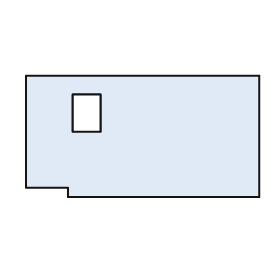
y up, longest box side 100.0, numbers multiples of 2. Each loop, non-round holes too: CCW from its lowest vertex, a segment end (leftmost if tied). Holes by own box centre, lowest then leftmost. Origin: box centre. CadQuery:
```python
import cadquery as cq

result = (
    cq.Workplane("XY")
    .moveTo(-32.0, -26.0)
    .lineTo(50.0, -26.0)
    .lineTo(50.0, 26.0)
    .lineTo(-50.0, 26.0)
    .lineTo(-50.0, -22.0)
    .lineTo(-32.0, -22.0)
    .close()
    .moveTo(-30.0, 2.0)
    .lineTo(-18.0, 2.0)
    .lineTo(-18.0, 18.0)
    .lineTo(-30.0, 18.0)
    .close()
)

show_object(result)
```